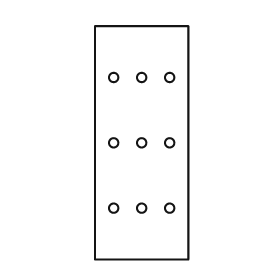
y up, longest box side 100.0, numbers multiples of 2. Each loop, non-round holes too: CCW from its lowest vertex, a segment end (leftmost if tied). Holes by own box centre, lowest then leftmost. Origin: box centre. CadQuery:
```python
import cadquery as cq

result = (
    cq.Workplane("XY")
    .moveTo(-20.0, -50.0)
    .lineTo(20.0, -50.0)
    .lineTo(20.0, 50.0)
    .lineTo(-20.0, 50.0)
    .close()
    .moveTo(-12.0, -28.0)
    .circle(2.0)
    .moveTo(0.0, -28.0)
    .circle(2.0)
    .moveTo(12.0, -28.0)
    .circle(2.0)
    .moveTo(-12.0, 0.0)
    .circle(2.0)
    .moveTo(0.0, 0.0)
    .circle(2.0)
    .moveTo(12.0, 0.0)
    .circle(2.0)
    .moveTo(-12.0, 28.0)
    .circle(2.0)
    .moveTo(0.0, 28.0)
    .circle(2.0)
    .moveTo(12.0, 28.0)
    .circle(2.0)
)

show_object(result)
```